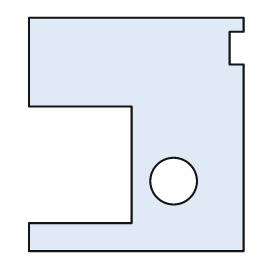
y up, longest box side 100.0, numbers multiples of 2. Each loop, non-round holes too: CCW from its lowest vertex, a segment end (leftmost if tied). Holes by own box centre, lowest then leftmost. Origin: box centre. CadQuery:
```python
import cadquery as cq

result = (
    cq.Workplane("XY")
    .moveTo(-46.0, -50.0)
    .lineTo(46.0, -50.0)
    .lineTo(46.0, 30.0)
    .lineTo(40.0, 30.0)
    .lineTo(40.0, 44.0)
    .lineTo(46.0, 44.0)
    .lineTo(46.0, 50.0)
    .lineTo(-46.0, 50.0)
    .lineTo(-46.0, 12.0)
    .lineTo(-2.0, 12.0)
    .lineTo(-2.0, -38.0)
    .lineTo(-46.0, -38.0)
    .close()
    .moveTo(16.0, -20.0)
    .circle(10.0)
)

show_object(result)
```